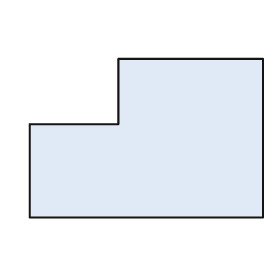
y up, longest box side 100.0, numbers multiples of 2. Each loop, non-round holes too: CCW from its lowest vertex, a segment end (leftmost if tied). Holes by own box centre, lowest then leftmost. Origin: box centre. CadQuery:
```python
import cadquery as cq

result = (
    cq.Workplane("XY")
    .moveTo(-50.0, -34.0)
    .lineTo(50.0, -34.0)
    .lineTo(50.0, 34.0)
    .lineTo(-12.0, 34.0)
    .lineTo(-12.0, 6.0)
    .lineTo(-50.0, 6.0)
    .close()
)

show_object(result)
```